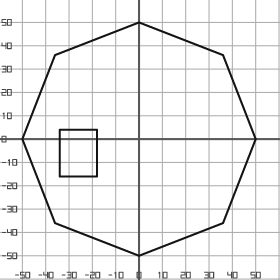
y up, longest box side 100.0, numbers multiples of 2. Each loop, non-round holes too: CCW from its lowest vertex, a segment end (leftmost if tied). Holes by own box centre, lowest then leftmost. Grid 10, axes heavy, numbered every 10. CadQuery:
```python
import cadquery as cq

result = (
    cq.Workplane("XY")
    .moveTo(0.0, -50.0)
    .lineTo(36.0, -36.0)
    .lineTo(50.0, 0.0)
    .lineTo(36.0, 36.0)
    .lineTo(0.0, 50.0)
    .lineTo(-36.0, 36.0)
    .lineTo(-50.0, 0.0)
    .lineTo(-36.0, -36.0)
    .close()
    .moveTo(-34.0, -16.0)
    .lineTo(-18.0, -16.0)
    .lineTo(-18.0, 4.0)
    .lineTo(-34.0, 4.0)
    .close()
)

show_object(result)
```